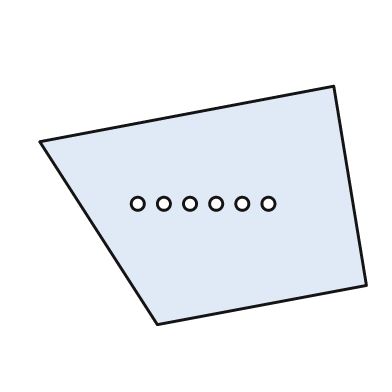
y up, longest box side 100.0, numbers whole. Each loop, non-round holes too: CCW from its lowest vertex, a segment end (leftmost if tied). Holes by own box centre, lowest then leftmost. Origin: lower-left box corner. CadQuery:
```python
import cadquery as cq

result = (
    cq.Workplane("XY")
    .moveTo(36.0, 0.0)
    .lineTo(100.0, 12.0)
    .lineTo(90.0, 73.0)
    .lineTo(0.0, 56.0)
    .close()
    .moveTo(30.0, 37.0)
    .circle(2.0)
    .moveTo(38.0, 37.0)
    .circle(2.0)
    .moveTo(46.0, 37.0)
    .circle(2.0)
    .moveTo(54.0, 37.0)
    .circle(2.0)
    .moveTo(62.0, 37.0)
    .circle(2.0)
    .moveTo(70.0, 37.0)
    .circle(2.0)
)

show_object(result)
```